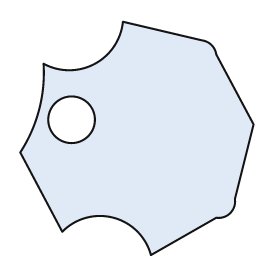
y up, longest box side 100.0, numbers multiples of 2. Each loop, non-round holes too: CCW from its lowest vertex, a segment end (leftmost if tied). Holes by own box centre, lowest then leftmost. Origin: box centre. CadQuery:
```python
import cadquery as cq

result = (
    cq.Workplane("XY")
    .moveTo(6.0, -50.0)
    .lineTo(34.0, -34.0)
    .threePointArc((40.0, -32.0), (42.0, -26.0))
    .lineTo(50.0, 6.0)
    .lineTo(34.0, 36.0)
    .threePointArc((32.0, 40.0), (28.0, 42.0))
    .lineTo(-6.0, 50.0)
    .threePointArc((-18.0, 32.0), (-40.0, 32.0))
    .threePointArc((-42.0, 12.0), (-50.0, -6.0))
    .lineTo(-32.0, -40.0)
    .threePointArc((-10.0, -34.0), (6.0, -50.0))
    .close()
    .moveTo(-28.0, 8.0)
    .circle(10.0)
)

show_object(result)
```